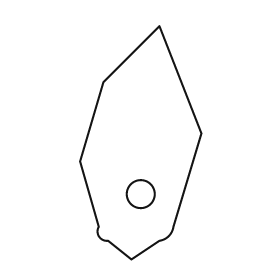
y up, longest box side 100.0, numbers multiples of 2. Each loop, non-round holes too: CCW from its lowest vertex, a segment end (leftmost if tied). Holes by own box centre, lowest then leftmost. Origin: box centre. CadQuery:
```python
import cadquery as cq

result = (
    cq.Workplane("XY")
    .moveTo(-4.0, -50.0)
    .lineTo(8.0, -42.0)
    .threePointArc((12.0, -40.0), (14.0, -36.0))
    .lineTo(26.0, 4.0)
    .lineTo(8.0, 50.0)
    .lineTo(-16.0, 26.0)
    .lineTo(-26.0, -8.0)
    .lineTo(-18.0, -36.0)
    .threePointArc((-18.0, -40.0), (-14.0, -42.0))
    .close()
    .moveTo(0.0, -22.0)
    .circle(6.0)
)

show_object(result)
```